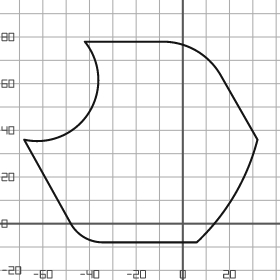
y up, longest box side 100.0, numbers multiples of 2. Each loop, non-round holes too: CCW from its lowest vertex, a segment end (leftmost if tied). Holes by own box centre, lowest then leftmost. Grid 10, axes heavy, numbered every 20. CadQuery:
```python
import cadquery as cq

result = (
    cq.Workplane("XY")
    .moveTo(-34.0, -8.0)
    .lineTo(6.0, -8.0)
    .threePointArc((22.0, 12.0), (32.0, 36.0))
    .lineTo(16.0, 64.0)
    .threePointArc((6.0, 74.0), (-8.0, 78.0))
    .lineTo(-42.0, 78.0)
    .threePointArc((-40.0, 48.0), (-68.0, 36.0))
    .lineTo(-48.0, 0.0)
    .threePointArc((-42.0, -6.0), (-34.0, -8.0))
    .close()
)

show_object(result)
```